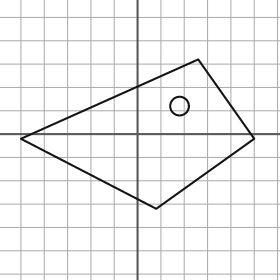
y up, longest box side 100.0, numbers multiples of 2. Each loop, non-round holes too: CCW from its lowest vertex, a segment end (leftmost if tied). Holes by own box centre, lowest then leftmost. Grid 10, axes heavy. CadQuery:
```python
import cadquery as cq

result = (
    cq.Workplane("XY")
    .moveTo(8.0, -32.0)
    .lineTo(50.0, -2.0)
    .lineTo(26.0, 32.0)
    .lineTo(-50.0, -2.0)
    .close()
    .moveTo(18.0, 12.0)
    .circle(4.0)
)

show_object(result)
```